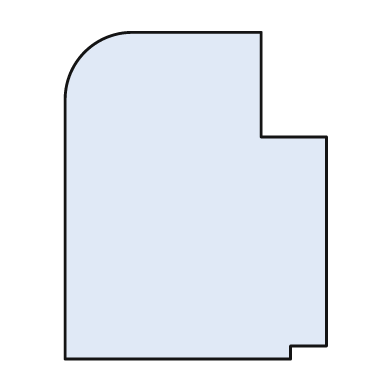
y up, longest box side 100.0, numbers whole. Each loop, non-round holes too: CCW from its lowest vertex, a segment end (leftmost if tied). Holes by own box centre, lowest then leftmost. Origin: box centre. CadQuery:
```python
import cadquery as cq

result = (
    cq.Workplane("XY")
    .moveTo(-40.0, -50.0)
    .lineTo(29.0, -50.0)
    .lineTo(29.0, -46.0)
    .lineTo(40.0, -46.0)
    .lineTo(40.0, 18.0)
    .lineTo(20.0, 18.0)
    .lineTo(20.0, 50.0)
    .lineTo(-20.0, 50.0)
    .threePointArc((-34.0, 44.0), (-40.0, 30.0))
    .close()
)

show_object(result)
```